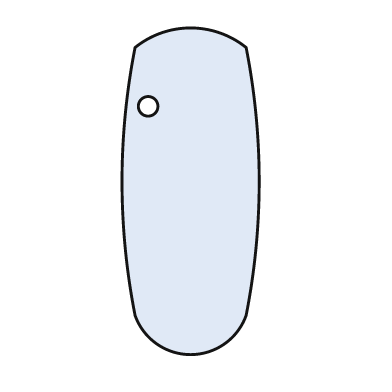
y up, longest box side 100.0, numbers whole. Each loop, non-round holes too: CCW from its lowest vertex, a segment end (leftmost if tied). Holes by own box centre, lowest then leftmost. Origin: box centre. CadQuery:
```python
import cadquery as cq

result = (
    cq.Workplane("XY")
    .moveTo(-17.0, -38.0)
    .threePointArc((0.0, -50.0), (17.0, -38.0))
    .threePointArc((21.0, 3.0), (17.0, 44.0))
    .threePointArc((0.0, 50.0), (-17.0, 44.0))
    .threePointArc((-21.0, 3.0), (-17.0, -38.0))
    .close()
    .moveTo(-13.0, 26.0)
    .circle(3.0)
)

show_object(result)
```